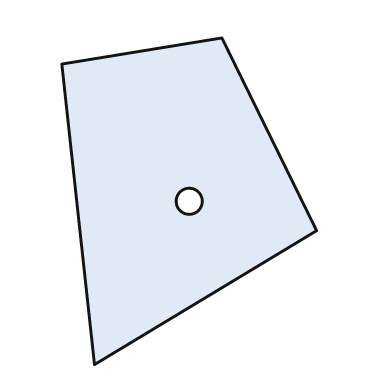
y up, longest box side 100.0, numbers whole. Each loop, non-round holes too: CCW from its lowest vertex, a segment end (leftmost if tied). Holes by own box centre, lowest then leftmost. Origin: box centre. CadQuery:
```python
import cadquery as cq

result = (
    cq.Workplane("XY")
    .moveTo(-29.0, -50.0)
    .lineTo(39.0, -9.0)
    .lineTo(10.0, 50.0)
    .lineTo(-39.0, 42.0)
    .close()
    .moveTo(0.0, 0.0)
    .circle(4.0)
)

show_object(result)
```